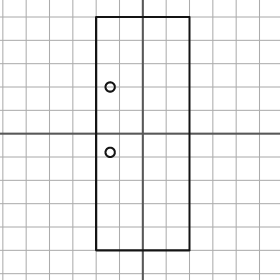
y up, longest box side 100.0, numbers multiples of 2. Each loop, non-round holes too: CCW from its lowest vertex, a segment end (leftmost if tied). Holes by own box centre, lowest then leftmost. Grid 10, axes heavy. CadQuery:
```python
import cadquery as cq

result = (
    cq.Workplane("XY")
    .moveTo(-20.0, -50.0)
    .lineTo(20.0, -50.0)
    .lineTo(20.0, 50.0)
    .lineTo(-20.0, 50.0)
    .close()
    .moveTo(-14.0, -8.0)
    .circle(2.0)
    .moveTo(-14.0, 20.0)
    .circle(2.0)
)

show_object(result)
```